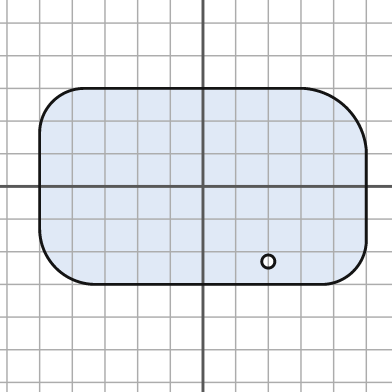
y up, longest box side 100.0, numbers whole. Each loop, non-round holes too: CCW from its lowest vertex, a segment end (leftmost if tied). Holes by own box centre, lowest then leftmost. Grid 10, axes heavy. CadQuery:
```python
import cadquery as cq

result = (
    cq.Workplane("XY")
    .moveTo(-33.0, -30.0)
    .lineTo(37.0, -30.0)
    .threePointArc((46.0, -26.0), (50.0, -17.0))
    .lineTo(50.0, 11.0)
    .threePointArc((44.0, 24.0), (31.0, 30.0))
    .lineTo(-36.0, 30.0)
    .threePointArc((-46.0, 26.0), (-50.0, 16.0))
    .lineTo(-50.0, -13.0)
    .threePointArc((-45.0, -25.0), (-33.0, -30.0))
    .close()
    .moveTo(20.0, -23.0)
    .circle(2.0)
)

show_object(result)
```